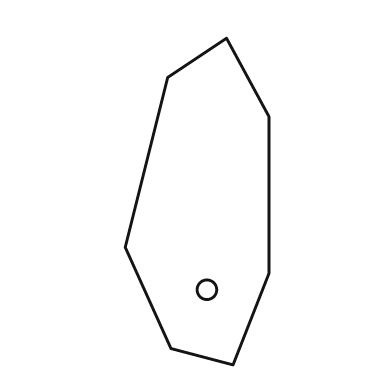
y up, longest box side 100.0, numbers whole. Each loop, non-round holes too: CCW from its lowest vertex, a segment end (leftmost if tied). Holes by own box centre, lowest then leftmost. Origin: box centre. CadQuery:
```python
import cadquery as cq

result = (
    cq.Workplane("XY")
    .moveTo(11.0, -50.0)
    .lineTo(22.0, -22.0)
    .lineTo(22.0, 26.0)
    .lineTo(9.0, 50.0)
    .lineTo(-9.0, 38.0)
    .lineTo(-22.0, -14.0)
    .lineTo(-8.0, -45.0)
    .close()
    .moveTo(3.0, -27.0)
    .circle(3.0)
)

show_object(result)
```